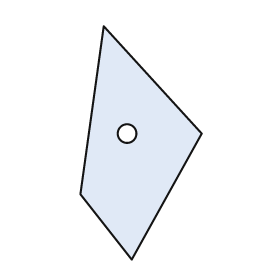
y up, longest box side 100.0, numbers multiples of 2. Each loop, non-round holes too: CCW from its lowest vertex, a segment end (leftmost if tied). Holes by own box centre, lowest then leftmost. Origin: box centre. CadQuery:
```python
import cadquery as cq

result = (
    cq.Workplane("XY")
    .moveTo(-4.0, -50.0)
    .lineTo(26.0, 4.0)
    .lineTo(-16.0, 50.0)
    .lineTo(-26.0, -22.0)
    .close()
    .moveTo(-6.0, 4.0)
    .circle(4.0)
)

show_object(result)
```